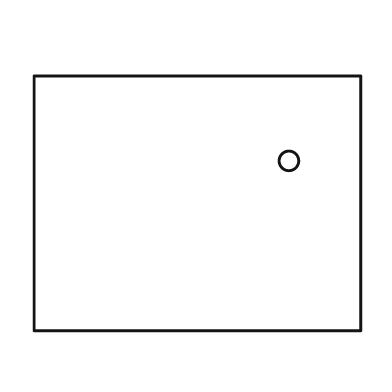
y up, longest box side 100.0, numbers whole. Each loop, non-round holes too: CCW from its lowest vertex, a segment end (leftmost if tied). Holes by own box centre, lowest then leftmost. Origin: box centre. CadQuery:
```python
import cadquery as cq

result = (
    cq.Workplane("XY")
    .moveTo(-50.0, -39.0)
    .lineTo(50.0, -39.0)
    .lineTo(50.0, 39.0)
    .lineTo(-50.0, 39.0)
    .close()
    .moveTo(28.0, 13.0)
    .circle(3.0)
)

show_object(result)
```